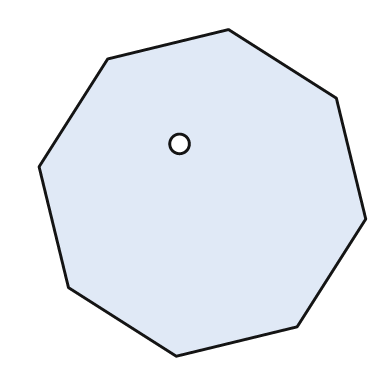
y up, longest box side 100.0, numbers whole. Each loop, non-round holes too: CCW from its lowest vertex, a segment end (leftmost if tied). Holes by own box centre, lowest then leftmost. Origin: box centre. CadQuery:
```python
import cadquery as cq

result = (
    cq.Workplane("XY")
    .moveTo(-8.0, -50.0)
    .lineTo(29.0, -41.0)
    .lineTo(50.0, -8.0)
    .lineTo(41.0, 29.0)
    .lineTo(8.0, 50.0)
    .lineTo(-29.0, 41.0)
    .lineTo(-50.0, 8.0)
    .lineTo(-41.0, -29.0)
    .close()
    .moveTo(-7.0, 15.0)
    .circle(3.0)
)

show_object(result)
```